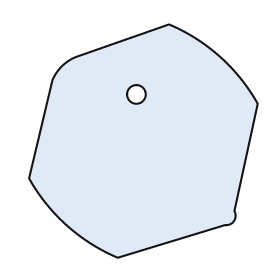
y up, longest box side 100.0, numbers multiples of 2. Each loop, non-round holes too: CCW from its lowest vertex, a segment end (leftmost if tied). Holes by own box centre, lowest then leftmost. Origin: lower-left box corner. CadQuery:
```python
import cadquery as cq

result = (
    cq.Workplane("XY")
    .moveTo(38.0, 0.0)
    .lineTo(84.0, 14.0)
    .threePointArc((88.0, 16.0), (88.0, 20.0))
    .lineTo(98.0, 66.0)
    .threePointArc((82.0, 86.0), (60.0, 100.0))
    .lineTo(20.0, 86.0)
    .threePointArc((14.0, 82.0), (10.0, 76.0))
    .lineTo(0.0, 34.0)
    .threePointArc((16.0, 14.0), (38.0, 0.0))
    .close()
    .moveTo(46.0, 70.0)
    .circle(4.0)
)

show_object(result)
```